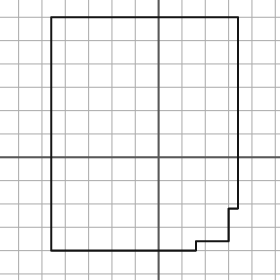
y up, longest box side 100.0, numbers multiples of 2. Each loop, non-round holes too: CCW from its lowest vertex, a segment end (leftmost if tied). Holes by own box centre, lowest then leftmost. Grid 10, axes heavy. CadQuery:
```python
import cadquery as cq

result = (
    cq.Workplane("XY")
    .moveTo(-46.0, -40.0)
    .lineTo(16.0, -40.0)
    .lineTo(16.0, -36.0)
    .lineTo(30.0, -36.0)
    .lineTo(30.0, -22.0)
    .lineTo(34.0, -22.0)
    .lineTo(34.0, 60.0)
    .lineTo(-46.0, 60.0)
    .close()
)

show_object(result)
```